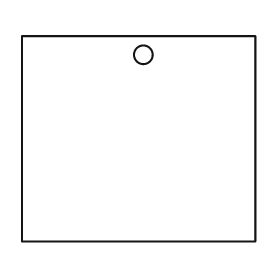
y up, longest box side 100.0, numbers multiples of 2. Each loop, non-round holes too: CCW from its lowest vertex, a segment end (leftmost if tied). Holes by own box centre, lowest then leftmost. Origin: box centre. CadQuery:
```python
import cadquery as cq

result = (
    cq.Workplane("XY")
    .moveTo(-50.0, -44.0)
    .lineTo(50.0, -44.0)
    .lineTo(50.0, 44.0)
    .lineTo(-50.0, 44.0)
    .close()
    .moveTo(2.0, 36.0)
    .circle(4.0)
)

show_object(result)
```